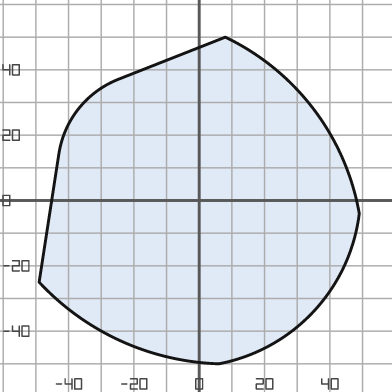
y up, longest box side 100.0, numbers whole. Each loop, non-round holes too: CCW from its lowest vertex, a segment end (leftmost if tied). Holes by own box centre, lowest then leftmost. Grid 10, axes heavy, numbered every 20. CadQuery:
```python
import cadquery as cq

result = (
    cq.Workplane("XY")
    .moveTo(6.0, -50.0)
    .threePointArc((35.0, -34.0), (49.0, -4.0))
    .threePointArc((35.0, 28.0), (8.0, 50.0))
    .lineTo(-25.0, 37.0)
    .threePointArc((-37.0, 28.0), (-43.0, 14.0))
    .lineTo(-49.0, -25.0)
    .threePointArc((-24.0, -43.0), (6.0, -50.0))
    .close()
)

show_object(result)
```